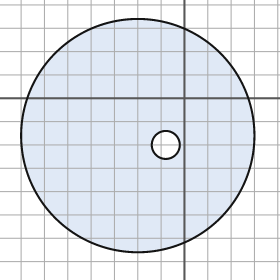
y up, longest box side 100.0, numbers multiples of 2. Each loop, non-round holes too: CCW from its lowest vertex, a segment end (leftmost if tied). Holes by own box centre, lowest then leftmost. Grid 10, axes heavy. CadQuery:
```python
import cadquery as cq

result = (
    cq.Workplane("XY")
    .moveTo(-20.0, -16.0)
    .circle(50.0)
    .moveTo(-8.0, -20.0)
    .circle(6.0)
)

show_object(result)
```